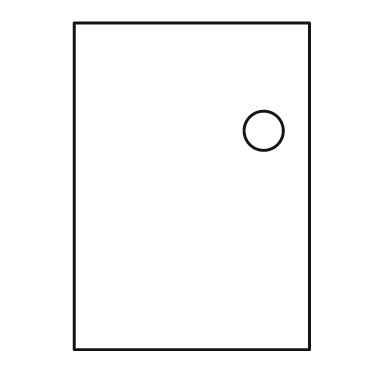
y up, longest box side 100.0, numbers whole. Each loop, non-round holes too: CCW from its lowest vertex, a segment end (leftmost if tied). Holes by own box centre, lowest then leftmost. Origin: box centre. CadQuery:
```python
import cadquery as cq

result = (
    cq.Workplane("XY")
    .moveTo(-36.0, -50.0)
    .lineTo(36.0, -50.0)
    .lineTo(36.0, 50.0)
    .lineTo(-36.0, 50.0)
    .close()
    .moveTo(22.0, 17.0)
    .circle(6.0)
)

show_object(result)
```